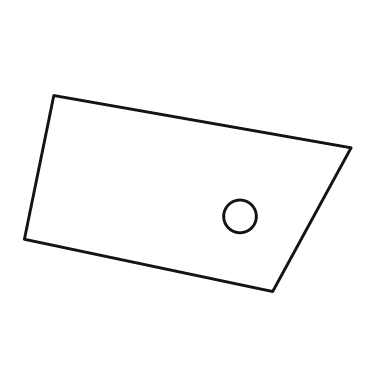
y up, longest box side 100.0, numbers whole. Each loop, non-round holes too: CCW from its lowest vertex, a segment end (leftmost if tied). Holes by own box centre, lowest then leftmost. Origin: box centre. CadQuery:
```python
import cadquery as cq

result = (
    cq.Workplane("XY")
    .moveTo(26.0, -30.0)
    .lineTo(50.0, 14.0)
    .lineTo(-41.0, 30.0)
    .lineTo(-50.0, -14.0)
    .close()
    .moveTo(16.0, -7.0)
    .circle(5.0)
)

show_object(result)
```